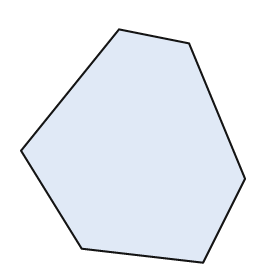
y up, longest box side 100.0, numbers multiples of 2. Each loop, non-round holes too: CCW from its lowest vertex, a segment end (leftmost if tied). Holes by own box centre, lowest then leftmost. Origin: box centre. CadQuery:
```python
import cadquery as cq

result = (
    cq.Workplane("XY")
    .moveTo(30.0, -50.0)
    .lineTo(48.0, -14.0)
    .lineTo(24.0, 44.0)
    .lineTo(-6.0, 50.0)
    .lineTo(-48.0, -2.0)
    .lineTo(-22.0, -44.0)
    .close()
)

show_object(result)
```